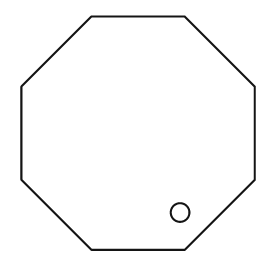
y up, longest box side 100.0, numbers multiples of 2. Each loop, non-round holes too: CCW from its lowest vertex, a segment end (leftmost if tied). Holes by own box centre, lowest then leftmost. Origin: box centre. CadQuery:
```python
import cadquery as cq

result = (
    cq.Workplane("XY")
    .moveTo(-20.0, -50.0)
    .lineTo(20.0, -50.0)
    .lineTo(50.0, -20.0)
    .lineTo(50.0, 20.0)
    .lineTo(20.0, 50.0)
    .lineTo(-20.0, 50.0)
    .lineTo(-50.0, 20.0)
    .lineTo(-50.0, -20.0)
    .close()
    .moveTo(18.0, -34.0)
    .circle(4.0)
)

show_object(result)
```